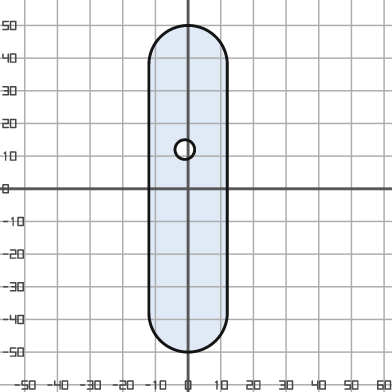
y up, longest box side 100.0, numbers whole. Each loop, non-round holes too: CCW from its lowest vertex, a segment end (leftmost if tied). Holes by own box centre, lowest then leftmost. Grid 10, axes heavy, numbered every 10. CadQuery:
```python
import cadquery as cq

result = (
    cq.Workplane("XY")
    .moveTo(-12.0, -38.0)
    .threePointArc((0.0, -50.0), (12.0, -38.0))
    .lineTo(12.0, 38.0)
    .threePointArc((0.0, 50.0), (-12.0, 38.0))
    .close()
    .moveTo(-1.0, 12.0)
    .circle(3.0)
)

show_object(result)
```